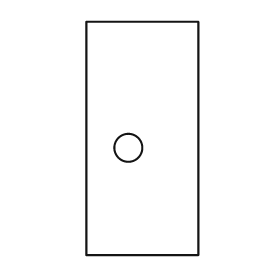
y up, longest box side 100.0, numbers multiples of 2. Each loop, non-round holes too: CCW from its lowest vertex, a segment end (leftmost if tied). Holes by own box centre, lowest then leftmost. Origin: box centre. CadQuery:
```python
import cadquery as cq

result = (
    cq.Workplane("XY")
    .moveTo(-24.0, -50.0)
    .lineTo(24.0, -50.0)
    .lineTo(24.0, 50.0)
    .lineTo(-24.0, 50.0)
    .close()
    .moveTo(-6.0, -4.0)
    .circle(6.0)
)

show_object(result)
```